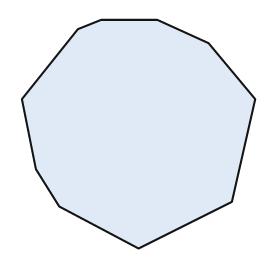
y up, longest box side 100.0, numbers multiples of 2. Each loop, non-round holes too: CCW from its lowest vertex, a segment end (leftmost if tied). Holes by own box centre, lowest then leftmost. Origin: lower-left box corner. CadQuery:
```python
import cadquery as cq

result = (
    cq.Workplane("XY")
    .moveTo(50.0, 0.0)
    .lineTo(90.0, 20.0)
    .lineTo(100.0, 64.0)
    .lineTo(80.0, 88.0)
    .lineTo(58.0, 98.0)
    .lineTo(34.0, 98.0)
    .lineTo(24.0, 94.0)
    .lineTo(0.0, 64.0)
    .lineTo(6.0, 34.0)
    .lineTo(16.0, 18.0)
    .close()
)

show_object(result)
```